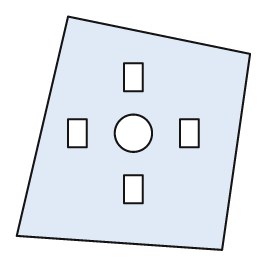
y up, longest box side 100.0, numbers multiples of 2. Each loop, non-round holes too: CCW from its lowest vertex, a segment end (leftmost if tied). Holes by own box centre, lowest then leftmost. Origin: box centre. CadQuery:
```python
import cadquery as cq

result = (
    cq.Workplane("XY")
    .moveTo(38.0, -50.0)
    .lineTo(50.0, 34.0)
    .lineTo(-28.0, 50.0)
    .lineTo(-50.0, -44.0)
    .close()
    .moveTo(-4.0, -30.0)
    .lineTo(4.0, -30.0)
    .lineTo(4.0, -18.0)
    .lineTo(-4.0, -18.0)
    .close()
    .moveTo(-28.0, -6.0)
    .lineTo(-20.0, -6.0)
    .lineTo(-20.0, 6.0)
    .lineTo(-28.0, 6.0)
    .close()
    .moveTo(0.0, 0.0)
    .circle(8.0)
    .moveTo(20.0, -6.0)
    .lineTo(28.0, -6.0)
    .lineTo(28.0, 6.0)
    .lineTo(20.0, 6.0)
    .close()
    .moveTo(-4.0, 18.0)
    .lineTo(4.0, 18.0)
    .lineTo(4.0, 30.0)
    .lineTo(-4.0, 30.0)
    .close()
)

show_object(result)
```